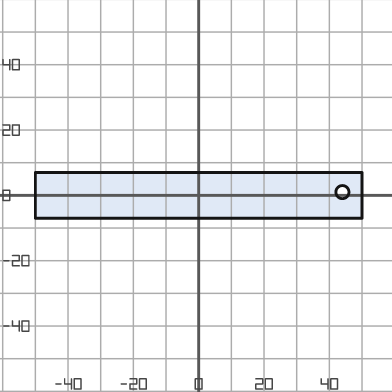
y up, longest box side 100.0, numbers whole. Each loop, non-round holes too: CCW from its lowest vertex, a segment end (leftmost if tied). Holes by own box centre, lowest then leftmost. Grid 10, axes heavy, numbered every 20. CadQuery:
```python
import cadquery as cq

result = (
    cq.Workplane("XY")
    .moveTo(-50.0, -7.0)
    .lineTo(50.0, -7.0)
    .lineTo(50.0, 7.0)
    .lineTo(-50.0, 7.0)
    .close()
    .moveTo(44.0, 1.0)
    .circle(2.0)
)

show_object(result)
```